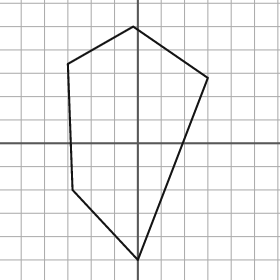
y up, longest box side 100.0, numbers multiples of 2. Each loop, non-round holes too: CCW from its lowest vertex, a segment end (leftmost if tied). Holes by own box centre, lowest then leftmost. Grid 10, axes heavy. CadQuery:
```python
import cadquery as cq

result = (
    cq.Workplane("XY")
    .moveTo(0.0, -50.0)
    .lineTo(30.0, 28.0)
    .lineTo(-2.0, 50.0)
    .lineTo(-30.0, 34.0)
    .lineTo(-28.0, -20.0)
    .close()
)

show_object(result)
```